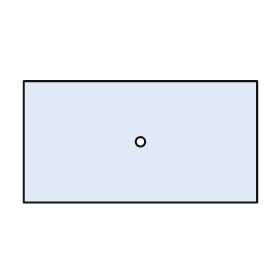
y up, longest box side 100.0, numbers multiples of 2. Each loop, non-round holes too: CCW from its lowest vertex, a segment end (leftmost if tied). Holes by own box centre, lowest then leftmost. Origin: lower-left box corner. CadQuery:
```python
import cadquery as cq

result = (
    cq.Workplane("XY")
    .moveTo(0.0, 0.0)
    .lineTo(100.0, 0.0)
    .lineTo(100.0, 52.0)
    .lineTo(0.0, 52.0)
    .close()
    .moveTo(50.0, 26.0)
    .circle(2.0)
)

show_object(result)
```